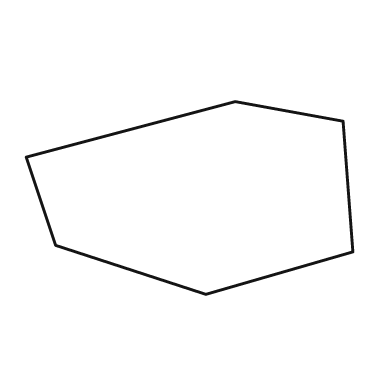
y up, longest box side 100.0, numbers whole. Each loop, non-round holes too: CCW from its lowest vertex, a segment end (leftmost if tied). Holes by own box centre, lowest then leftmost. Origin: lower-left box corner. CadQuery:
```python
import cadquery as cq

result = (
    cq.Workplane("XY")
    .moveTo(55.0, 0.0)
    .lineTo(100.0, 13.0)
    .lineTo(97.0, 53.0)
    .lineTo(64.0, 59.0)
    .lineTo(0.0, 42.0)
    .lineTo(9.0, 15.0)
    .close()
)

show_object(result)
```